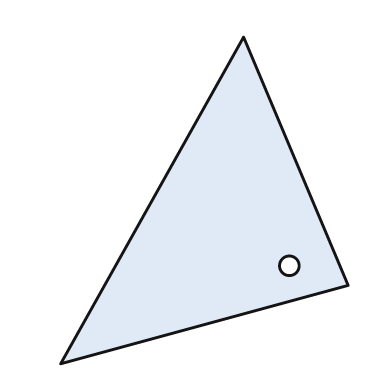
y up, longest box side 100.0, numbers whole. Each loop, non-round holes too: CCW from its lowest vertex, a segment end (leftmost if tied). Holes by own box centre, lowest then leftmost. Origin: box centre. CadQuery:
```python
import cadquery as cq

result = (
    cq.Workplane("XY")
    .moveTo(-44.0, -50.0)
    .lineTo(44.0, -26.0)
    .lineTo(12.0, 50.0)
    .close()
    .moveTo(26.0, -20.0)
    .circle(3.0)
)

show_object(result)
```